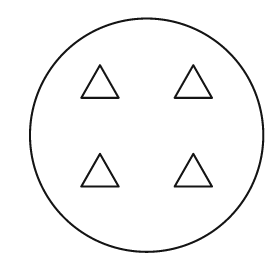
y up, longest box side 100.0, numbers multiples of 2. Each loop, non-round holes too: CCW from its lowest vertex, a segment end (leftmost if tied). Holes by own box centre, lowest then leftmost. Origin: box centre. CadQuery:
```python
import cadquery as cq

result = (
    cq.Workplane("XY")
    .moveTo(0.0, 0.0)
    .circle(50.0)
    .moveTo(-28.0, -22.0)
    .lineTo(-12.0, -22.0)
    .lineTo(-20.0, -8.0)
    .close()
    .moveTo(12.0, -22.0)
    .lineTo(28.0, -22.0)
    .lineTo(20.0, -8.0)
    .close()
    .moveTo(-28.0, 16.0)
    .lineTo(-12.0, 16.0)
    .lineTo(-20.0, 30.0)
    .close()
    .moveTo(12.0, 16.0)
    .lineTo(28.0, 16.0)
    .lineTo(20.0, 30.0)
    .close()
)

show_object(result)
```